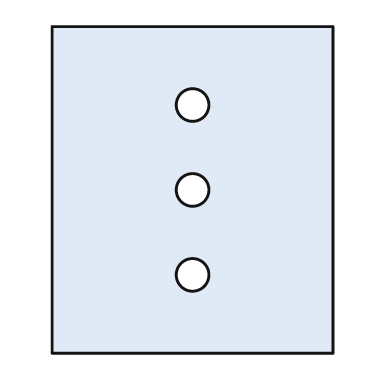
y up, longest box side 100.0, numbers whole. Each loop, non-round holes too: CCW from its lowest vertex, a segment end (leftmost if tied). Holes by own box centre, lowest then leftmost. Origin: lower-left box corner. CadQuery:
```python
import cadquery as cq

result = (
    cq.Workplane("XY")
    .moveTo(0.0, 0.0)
    .lineTo(86.0, 0.0)
    .lineTo(86.0, 100.0)
    .lineTo(0.0, 100.0)
    .close()
    .moveTo(43.0, 24.0)
    .circle(5.0)
    .moveTo(43.0, 50.0)
    .circle(5.0)
    .moveTo(43.0, 76.0)
    .circle(5.0)
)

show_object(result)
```